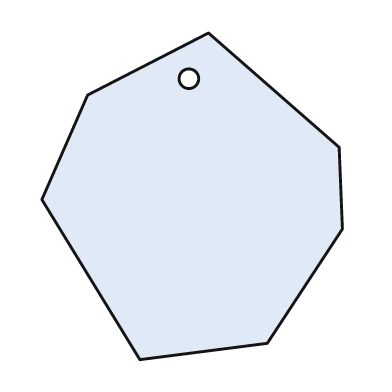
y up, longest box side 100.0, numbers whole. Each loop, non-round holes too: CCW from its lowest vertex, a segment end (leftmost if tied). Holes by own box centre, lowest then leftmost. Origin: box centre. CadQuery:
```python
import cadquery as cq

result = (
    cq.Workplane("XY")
    .moveTo(-16.0, -50.0)
    .lineTo(23.0, -45.0)
    .lineTo(46.0, -10.0)
    .lineTo(45.0, 15.0)
    .lineTo(5.0, 50.0)
    .lineTo(-32.0, 31.0)
    .lineTo(-46.0, -1.0)
    .close()
    .moveTo(-1.0, 36.0)
    .circle(3.0)
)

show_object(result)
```